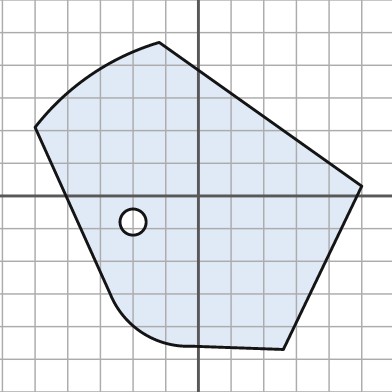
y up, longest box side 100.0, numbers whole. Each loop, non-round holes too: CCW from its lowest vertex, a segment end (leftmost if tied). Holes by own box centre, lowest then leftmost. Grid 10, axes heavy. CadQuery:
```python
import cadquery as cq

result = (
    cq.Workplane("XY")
    .moveTo(26.0, -47.0)
    .lineTo(50.0, 3.0)
    .lineTo(-12.0, 47.0)
    .threePointArc((-33.0, 37.0), (-50.0, 21.0))
    .lineTo(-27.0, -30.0)
    .threePointArc((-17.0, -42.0), (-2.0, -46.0))
    .close()
    .moveTo(-20.0, -8.0)
    .circle(4.0)
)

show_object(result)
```